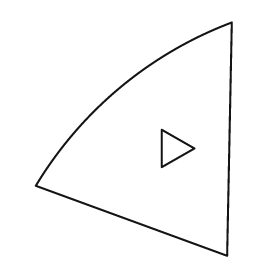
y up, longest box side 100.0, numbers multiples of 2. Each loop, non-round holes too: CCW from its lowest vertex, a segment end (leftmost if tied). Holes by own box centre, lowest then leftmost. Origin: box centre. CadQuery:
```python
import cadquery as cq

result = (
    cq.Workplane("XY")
    .moveTo(40.0, -50.0)
    .lineTo(42.0, 50.0)
    .threePointArc((-6.0, 22.0), (-42.0, -20.0))
    .close()
    .moveTo(12.0, -12.0)
    .lineTo(26.0, -4.0)
    .lineTo(12.0, 4.0)
    .close()
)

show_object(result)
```